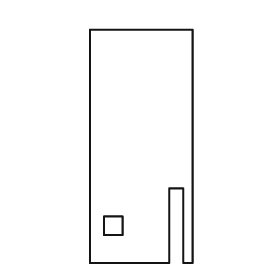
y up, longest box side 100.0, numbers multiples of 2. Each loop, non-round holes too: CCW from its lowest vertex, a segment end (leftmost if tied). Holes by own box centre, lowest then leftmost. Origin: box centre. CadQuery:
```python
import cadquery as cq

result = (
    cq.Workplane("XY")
    .moveTo(-22.0, -50.0)
    .lineTo(12.0, -50.0)
    .lineTo(12.0, -18.0)
    .lineTo(18.0, -18.0)
    .lineTo(18.0, -50.0)
    .lineTo(22.0, -50.0)
    .lineTo(22.0, 50.0)
    .lineTo(-22.0, 50.0)
    .close()
    .moveTo(-16.0, -38.0)
    .lineTo(-8.0, -38.0)
    .lineTo(-8.0, -30.0)
    .lineTo(-16.0, -30.0)
    .close()
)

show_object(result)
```